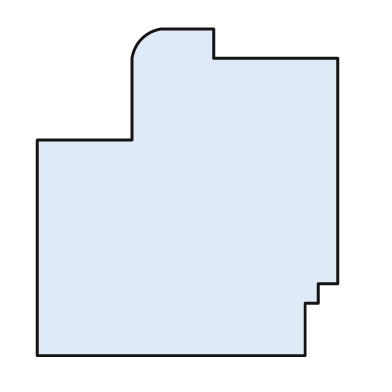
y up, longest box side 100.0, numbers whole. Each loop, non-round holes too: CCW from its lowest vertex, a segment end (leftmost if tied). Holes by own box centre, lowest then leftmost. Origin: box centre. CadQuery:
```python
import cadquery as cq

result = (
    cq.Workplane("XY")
    .moveTo(-46.0, -50.0)
    .lineTo(36.0, -50.0)
    .lineTo(36.0, -34.0)
    .lineTo(40.0, -34.0)
    .lineTo(40.0, -28.0)
    .lineTo(46.0, -28.0)
    .lineTo(46.0, 41.0)
    .lineTo(8.0, 41.0)
    .lineTo(8.0, 50.0)
    .lineTo(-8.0, 50.0)
    .threePointArc((-14.0, 47.0), (-17.0, 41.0))
    .lineTo(-17.0, 16.0)
    .lineTo(-46.0, 16.0)
    .close()
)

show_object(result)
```